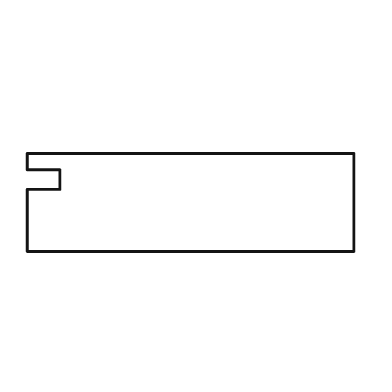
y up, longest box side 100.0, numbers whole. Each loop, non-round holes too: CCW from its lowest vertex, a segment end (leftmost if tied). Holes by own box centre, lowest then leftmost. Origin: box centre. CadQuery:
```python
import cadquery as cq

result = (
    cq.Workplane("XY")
    .moveTo(-50.0, -15.0)
    .lineTo(50.0, -15.0)
    .lineTo(50.0, 15.0)
    .lineTo(-50.0, 15.0)
    .lineTo(-50.0, 10.0)
    .lineTo(-40.0, 10.0)
    .lineTo(-40.0, 4.0)
    .lineTo(-50.0, 4.0)
    .close()
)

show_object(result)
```